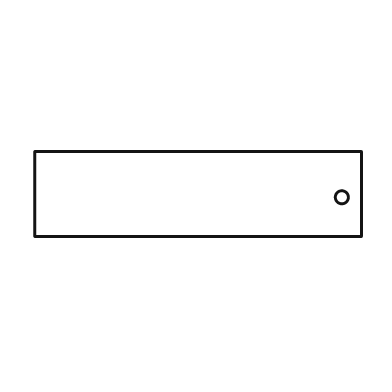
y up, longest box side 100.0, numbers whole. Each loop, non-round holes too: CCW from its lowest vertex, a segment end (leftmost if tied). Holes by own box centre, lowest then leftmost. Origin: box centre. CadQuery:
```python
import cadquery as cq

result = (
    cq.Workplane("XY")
    .moveTo(-50.0, -13.0)
    .lineTo(50.0, -13.0)
    .lineTo(50.0, 13.0)
    .lineTo(-50.0, 13.0)
    .close()
    .moveTo(44.0, -1.0)
    .circle(2.0)
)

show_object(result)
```